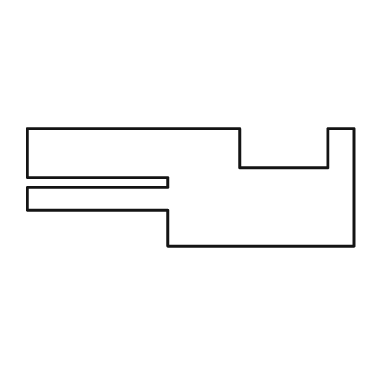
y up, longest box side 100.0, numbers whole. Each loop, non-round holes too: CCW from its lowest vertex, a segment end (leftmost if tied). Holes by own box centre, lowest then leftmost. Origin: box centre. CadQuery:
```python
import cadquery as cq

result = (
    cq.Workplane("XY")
    .moveTo(-7.0, -18.0)
    .lineTo(50.0, -18.0)
    .lineTo(50.0, 18.0)
    .lineTo(42.0, 18.0)
    .lineTo(42.0, 6.0)
    .lineTo(15.0, 6.0)
    .lineTo(15.0, 18.0)
    .lineTo(-50.0, 18.0)
    .lineTo(-50.0, 3.0)
    .lineTo(-7.0, 3.0)
    .lineTo(-7.0, 0.0)
    .lineTo(-50.0, 0.0)
    .lineTo(-50.0, -7.0)
    .lineTo(-7.0, -7.0)
    .close()
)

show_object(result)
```